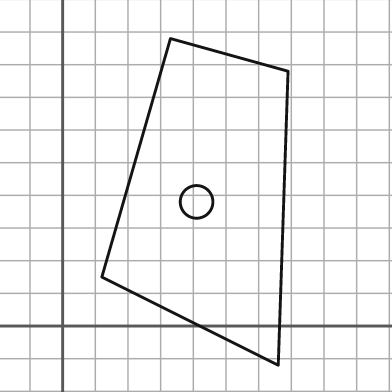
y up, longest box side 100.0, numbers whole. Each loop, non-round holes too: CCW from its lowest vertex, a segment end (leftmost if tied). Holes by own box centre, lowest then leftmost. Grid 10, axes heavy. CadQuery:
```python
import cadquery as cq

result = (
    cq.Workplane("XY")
    .moveTo(66.0, -12.0)
    .lineTo(69.0, 78.0)
    .lineTo(33.0, 88.0)
    .lineTo(12.0, 15.0)
    .close()
    .moveTo(41.0, 38.0)
    .circle(5.0)
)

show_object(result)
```